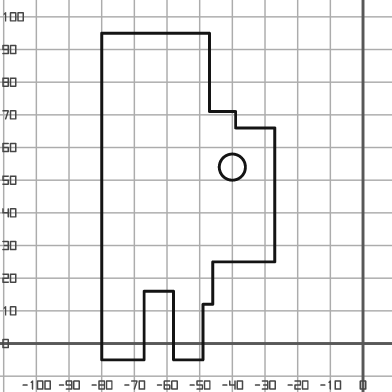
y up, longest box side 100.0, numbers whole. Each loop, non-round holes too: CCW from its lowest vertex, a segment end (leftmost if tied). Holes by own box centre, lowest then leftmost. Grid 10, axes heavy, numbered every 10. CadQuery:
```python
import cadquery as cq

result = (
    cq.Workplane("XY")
    .moveTo(-80.0, -5.0)
    .lineTo(-67.0, -5.0)
    .lineTo(-67.0, 16.0)
    .lineTo(-58.0, 16.0)
    .lineTo(-58.0, -5.0)
    .lineTo(-49.0, -5.0)
    .lineTo(-49.0, 12.0)
    .lineTo(-46.0, 12.0)
    .lineTo(-46.0, 25.0)
    .lineTo(-27.0, 25.0)
    .lineTo(-27.0, 66.0)
    .lineTo(-39.0, 66.0)
    .lineTo(-39.0, 71.0)
    .lineTo(-47.0, 71.0)
    .lineTo(-47.0, 95.0)
    .lineTo(-80.0, 95.0)
    .close()
    .moveTo(-40.0, 54.0)
    .circle(4.0)
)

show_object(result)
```